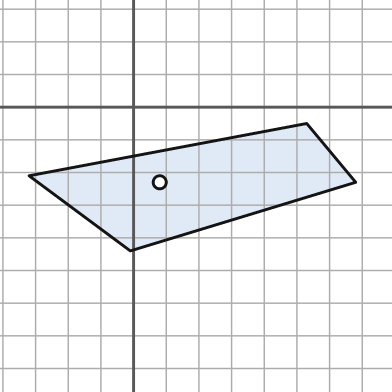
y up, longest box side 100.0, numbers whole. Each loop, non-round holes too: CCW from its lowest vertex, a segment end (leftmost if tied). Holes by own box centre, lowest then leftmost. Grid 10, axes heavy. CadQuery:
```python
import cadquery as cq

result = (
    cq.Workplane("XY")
    .moveTo(-1.0, -44.0)
    .lineTo(68.0, -23.0)
    .lineTo(53.0, -5.0)
    .lineTo(-32.0, -21.0)
    .close()
    .moveTo(8.0, -23.0)
    .circle(2.0)
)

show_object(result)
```